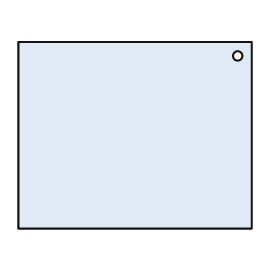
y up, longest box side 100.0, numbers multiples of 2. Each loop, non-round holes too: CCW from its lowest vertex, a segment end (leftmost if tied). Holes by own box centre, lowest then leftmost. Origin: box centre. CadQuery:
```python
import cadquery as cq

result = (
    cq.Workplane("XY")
    .moveTo(-50.0, -40.0)
    .lineTo(50.0, -40.0)
    .lineTo(50.0, 40.0)
    .lineTo(-50.0, 40.0)
    .close()
    .moveTo(44.0, 34.0)
    .circle(2.0)
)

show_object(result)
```